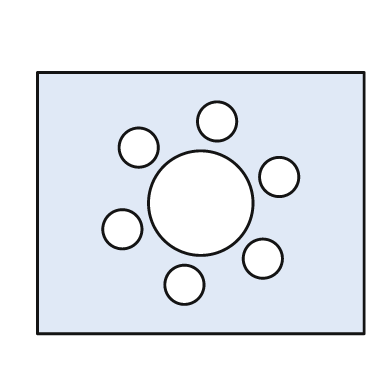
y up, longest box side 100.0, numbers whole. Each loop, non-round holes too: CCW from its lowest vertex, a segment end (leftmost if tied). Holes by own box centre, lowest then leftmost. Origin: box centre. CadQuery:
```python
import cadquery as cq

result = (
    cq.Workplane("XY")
    .moveTo(-50.0, -40.0)
    .lineTo(50.0, -40.0)
    .lineTo(50.0, 40.0)
    .lineTo(-50.0, 40.0)
    .close()
    .moveTo(-5.0, -25.0)
    .circle(6.0)
    .moveTo(19.0, -17.0)
    .circle(6.0)
    .moveTo(-24.0, -8.0)
    .circle(6.0)
    .moveTo(0.0, 0.0)
    .circle(16.0)
    .moveTo(24.0, 8.0)
    .circle(6.0)
    .moveTo(-19.0, 17.0)
    .circle(6.0)
    .moveTo(5.0, 25.0)
    .circle(6.0)
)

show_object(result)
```